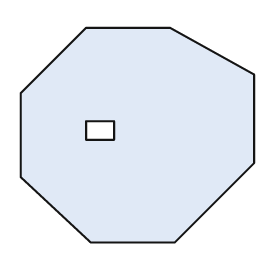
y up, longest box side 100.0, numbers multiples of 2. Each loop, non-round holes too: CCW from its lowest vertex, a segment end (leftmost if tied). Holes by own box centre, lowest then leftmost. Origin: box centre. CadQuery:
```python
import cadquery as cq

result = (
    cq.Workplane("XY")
    .moveTo(-20.0, -46.0)
    .lineTo(16.0, -46.0)
    .lineTo(50.0, -12.0)
    .lineTo(50.0, 26.0)
    .lineTo(14.0, 46.0)
    .lineTo(-22.0, 46.0)
    .lineTo(-50.0, 18.0)
    .lineTo(-50.0, -18.0)
    .close()
    .moveTo(-22.0, -2.0)
    .lineTo(-10.0, -2.0)
    .lineTo(-10.0, 6.0)
    .lineTo(-22.0, 6.0)
    .close()
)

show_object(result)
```